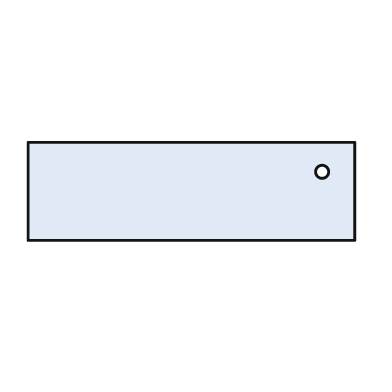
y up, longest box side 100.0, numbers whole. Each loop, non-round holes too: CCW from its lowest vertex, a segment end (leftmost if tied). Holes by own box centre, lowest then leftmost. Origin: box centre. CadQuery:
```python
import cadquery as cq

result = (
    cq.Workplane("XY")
    .moveTo(-50.0, -15.0)
    .lineTo(50.0, -15.0)
    .lineTo(50.0, 15.0)
    .lineTo(-50.0, 15.0)
    .close()
    .moveTo(40.0, 6.0)
    .circle(2.0)
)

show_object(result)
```